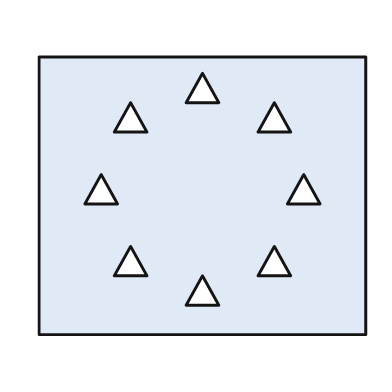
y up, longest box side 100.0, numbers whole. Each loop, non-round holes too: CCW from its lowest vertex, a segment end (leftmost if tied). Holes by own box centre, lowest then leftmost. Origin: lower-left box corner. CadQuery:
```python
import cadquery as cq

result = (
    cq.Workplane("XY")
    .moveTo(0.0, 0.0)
    .lineTo(100.0, 0.0)
    .lineTo(100.0, 85.0)
    .lineTo(0.0, 85.0)
    .close()
    .moveTo(45.0, 9.0)
    .lineTo(55.0, 9.0)
    .lineTo(50.0, 18.0)
    .close()
    .moveTo(23.0, 18.0)
    .lineTo(33.0, 18.0)
    .lineTo(28.0, 27.0)
    .close()
    .moveTo(67.0, 18.0)
    .lineTo(77.0, 18.0)
    .lineTo(72.0, 27.0)
    .close()
    .moveTo(14.0, 40.0)
    .lineTo(24.0, 40.0)
    .lineTo(19.0, 49.0)
    .close()
    .moveTo(76.0, 40.0)
    .lineTo(86.0, 40.0)
    .lineTo(81.0, 49.0)
    .close()
    .moveTo(23.0, 62.0)
    .lineTo(33.0, 62.0)
    .lineTo(28.0, 71.0)
    .close()
    .moveTo(67.0, 62.0)
    .lineTo(77.0, 62.0)
    .lineTo(72.0, 71.0)
    .close()
    .moveTo(45.0, 71.0)
    .lineTo(55.0, 71.0)
    .lineTo(50.0, 80.0)
    .close()
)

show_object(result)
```